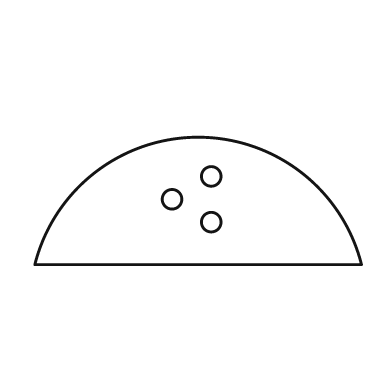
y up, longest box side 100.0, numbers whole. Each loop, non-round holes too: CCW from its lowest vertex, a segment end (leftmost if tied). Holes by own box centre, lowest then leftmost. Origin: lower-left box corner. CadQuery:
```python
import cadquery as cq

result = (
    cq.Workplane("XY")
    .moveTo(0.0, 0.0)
    .lineTo(100.0, 0.0)
    .threePointArc((50.0, 39.0), (0.0, 0.0))
    .close()
    .moveTo(54.0, 13.0)
    .circle(3.0)
    .moveTo(42.0, 20.0)
    .circle(3.0)
    .moveTo(54.0, 27.0)
    .circle(3.0)
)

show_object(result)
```